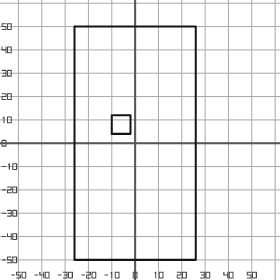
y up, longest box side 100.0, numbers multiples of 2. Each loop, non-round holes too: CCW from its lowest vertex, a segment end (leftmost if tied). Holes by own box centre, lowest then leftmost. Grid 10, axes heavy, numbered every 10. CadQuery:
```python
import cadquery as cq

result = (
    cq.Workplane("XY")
    .moveTo(-26.0, -50.0)
    .lineTo(26.0, -50.0)
    .lineTo(26.0, 50.0)
    .lineTo(-26.0, 50.0)
    .close()
    .moveTo(-10.0, 4.0)
    .lineTo(-2.0, 4.0)
    .lineTo(-2.0, 12.0)
    .lineTo(-10.0, 12.0)
    .close()
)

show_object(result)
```